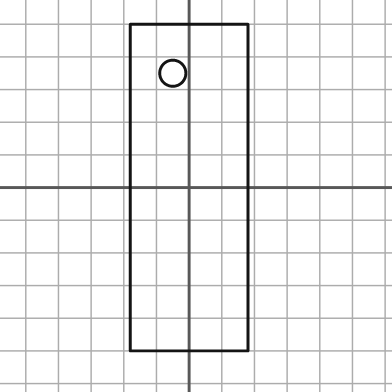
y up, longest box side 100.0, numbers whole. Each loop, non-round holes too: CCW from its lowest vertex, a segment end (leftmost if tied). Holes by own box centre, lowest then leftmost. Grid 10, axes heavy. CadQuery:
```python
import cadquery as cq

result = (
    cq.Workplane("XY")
    .moveTo(-18.0, -50.0)
    .lineTo(18.0, -50.0)
    .lineTo(18.0, 50.0)
    .lineTo(-18.0, 50.0)
    .close()
    .moveTo(-5.0, 35.0)
    .circle(4.0)
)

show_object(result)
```